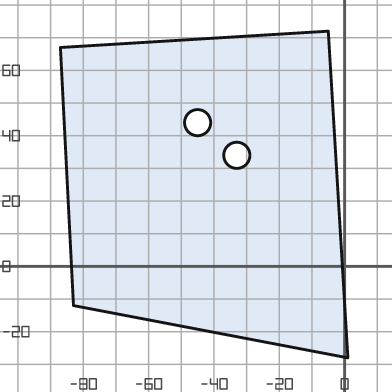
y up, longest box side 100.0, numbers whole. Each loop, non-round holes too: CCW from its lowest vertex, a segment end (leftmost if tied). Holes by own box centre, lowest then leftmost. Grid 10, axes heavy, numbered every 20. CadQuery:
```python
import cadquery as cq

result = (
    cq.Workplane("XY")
    .moveTo(1.0, -28.0)
    .lineTo(-5.0, 72.0)
    .lineTo(-87.0, 67.0)
    .lineTo(-83.0, -12.0)
    .close()
    .moveTo(-33.0, 34.0)
    .circle(4.0)
    .moveTo(-45.0, 44.0)
    .circle(4.0)
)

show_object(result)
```